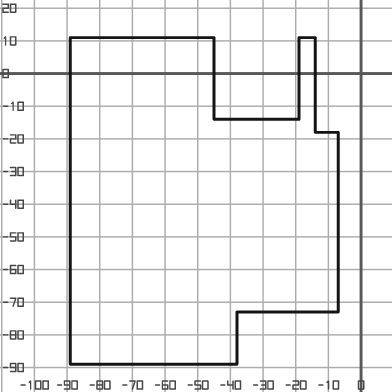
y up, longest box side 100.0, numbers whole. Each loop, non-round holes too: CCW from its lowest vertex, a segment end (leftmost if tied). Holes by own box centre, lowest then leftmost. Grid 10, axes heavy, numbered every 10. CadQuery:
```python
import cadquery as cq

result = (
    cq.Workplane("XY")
    .moveTo(-89.0, -89.0)
    .lineTo(-38.0, -89.0)
    .lineTo(-38.0, -73.0)
    .lineTo(-7.0, -73.0)
    .lineTo(-7.0, -18.0)
    .lineTo(-14.0, -18.0)
    .lineTo(-14.0, 11.0)
    .lineTo(-19.0, 11.0)
    .lineTo(-19.0, -14.0)
    .lineTo(-45.0, -14.0)
    .lineTo(-45.0, 11.0)
    .lineTo(-89.0, 11.0)
    .close()
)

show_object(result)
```